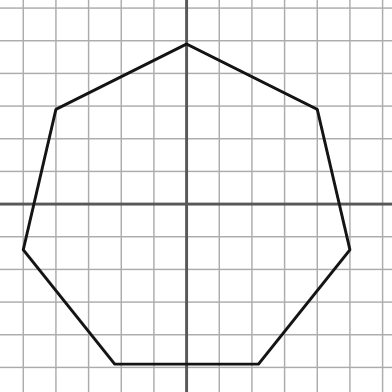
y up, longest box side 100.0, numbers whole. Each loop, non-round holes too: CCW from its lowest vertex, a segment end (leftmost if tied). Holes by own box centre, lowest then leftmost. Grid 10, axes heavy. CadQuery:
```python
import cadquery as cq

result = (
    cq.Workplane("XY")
    .moveTo(-22.0, -49.0)
    .lineTo(22.0, -49.0)
    .lineTo(50.0, -14.0)
    .lineTo(40.0, 29.0)
    .lineTo(0.0, 49.0)
    .lineTo(-40.0, 29.0)
    .lineTo(-50.0, -14.0)
    .close()
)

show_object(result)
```